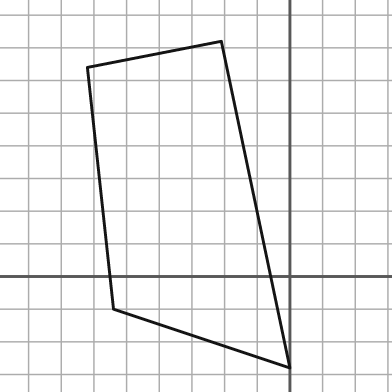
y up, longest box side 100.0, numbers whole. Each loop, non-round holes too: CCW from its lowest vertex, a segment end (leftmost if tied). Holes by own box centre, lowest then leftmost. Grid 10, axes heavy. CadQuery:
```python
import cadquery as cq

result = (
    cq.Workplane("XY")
    .moveTo(0.0, -28.0)
    .lineTo(-21.0, 72.0)
    .lineTo(-62.0, 64.0)
    .lineTo(-54.0, -10.0)
    .close()
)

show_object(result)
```